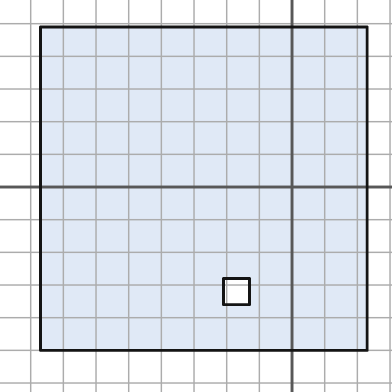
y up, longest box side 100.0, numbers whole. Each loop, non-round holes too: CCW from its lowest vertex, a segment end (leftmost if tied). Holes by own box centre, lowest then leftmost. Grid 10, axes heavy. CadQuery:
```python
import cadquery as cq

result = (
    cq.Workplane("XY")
    .moveTo(-77.0, -50.0)
    .lineTo(23.0, -50.0)
    .lineTo(23.0, 49.0)
    .lineTo(-77.0, 49.0)
    .close()
    .moveTo(-21.0, -36.0)
    .lineTo(-13.0, -36.0)
    .lineTo(-13.0, -28.0)
    .lineTo(-21.0, -28.0)
    .close()
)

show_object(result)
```